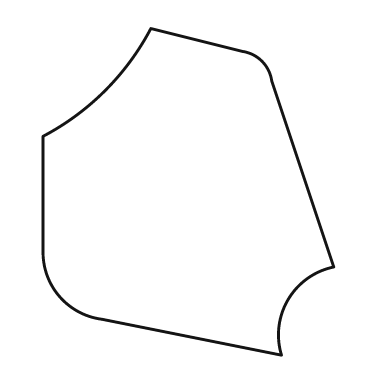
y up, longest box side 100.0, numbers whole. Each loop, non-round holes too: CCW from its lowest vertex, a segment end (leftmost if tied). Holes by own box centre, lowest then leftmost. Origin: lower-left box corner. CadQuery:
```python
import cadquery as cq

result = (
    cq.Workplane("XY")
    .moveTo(73.0, 0.0)
    .threePointArc((75.0, 17.0), (89.0, 27.0))
    .lineTo(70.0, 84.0)
    .threePointArc((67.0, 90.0), (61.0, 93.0))
    .lineTo(33.0, 100.0)
    .threePointArc((19.0, 81.0), (0.0, 67.0))
    .lineTo(0.0, 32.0)
    .threePointArc((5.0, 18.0), (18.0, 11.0))
    .close()
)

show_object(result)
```